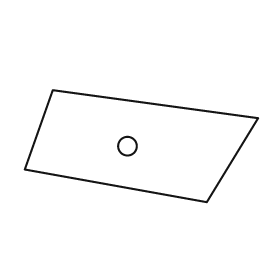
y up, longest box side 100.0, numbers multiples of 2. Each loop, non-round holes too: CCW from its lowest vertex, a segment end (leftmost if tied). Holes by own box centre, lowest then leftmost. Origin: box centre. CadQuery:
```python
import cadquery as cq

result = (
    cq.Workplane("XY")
    .moveTo(28.0, -24.0)
    .lineTo(50.0, 12.0)
    .lineTo(-38.0, 24.0)
    .lineTo(-50.0, -10.0)
    .close()
    .moveTo(-6.0, 0.0)
    .circle(4.0)
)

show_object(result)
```